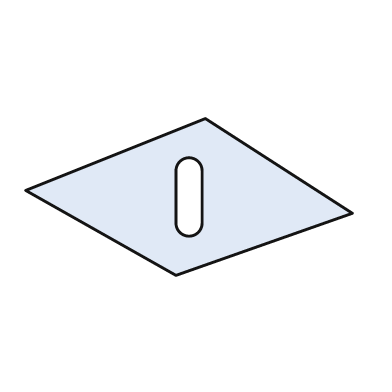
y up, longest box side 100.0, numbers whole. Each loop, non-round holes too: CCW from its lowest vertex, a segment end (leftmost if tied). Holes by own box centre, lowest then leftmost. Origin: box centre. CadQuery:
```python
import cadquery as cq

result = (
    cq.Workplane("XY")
    .moveTo(-4.0, -24.0)
    .lineTo(50.0, -5.0)
    .lineTo(5.0, 24.0)
    .lineTo(-50.0, 2.0)
    .close()
    .moveTo(-4.0, -8.0)
    .threePointArc((0.0, -12.0), (4.0, -8.0))
    .lineTo(4.0, 8.0)
    .threePointArc((0.0, 12.0), (-4.0, 8.0))
    .close()
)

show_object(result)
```